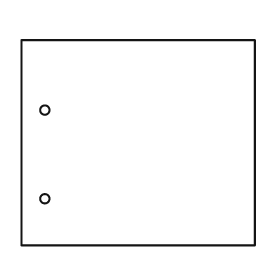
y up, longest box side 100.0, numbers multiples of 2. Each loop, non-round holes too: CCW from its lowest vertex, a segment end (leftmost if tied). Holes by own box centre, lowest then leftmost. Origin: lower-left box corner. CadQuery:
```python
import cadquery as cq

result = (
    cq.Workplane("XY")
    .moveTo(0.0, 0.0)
    .lineTo(100.0, 0.0)
    .lineTo(100.0, 88.0)
    .lineTo(0.0, 88.0)
    .close()
    .moveTo(10.0, 20.0)
    .circle(2.0)
    .moveTo(10.0, 58.0)
    .circle(2.0)
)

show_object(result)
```